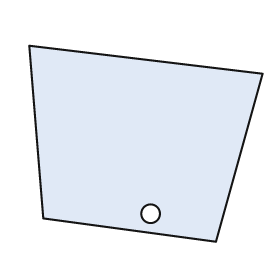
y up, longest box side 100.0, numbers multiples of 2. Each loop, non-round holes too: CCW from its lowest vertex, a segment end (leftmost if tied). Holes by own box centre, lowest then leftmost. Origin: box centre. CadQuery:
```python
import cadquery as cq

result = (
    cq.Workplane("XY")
    .moveTo(30.0, -42.0)
    .lineTo(50.0, 30.0)
    .lineTo(-50.0, 42.0)
    .lineTo(-44.0, -32.0)
    .close()
    .moveTo(2.0, -30.0)
    .circle(4.0)
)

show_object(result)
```